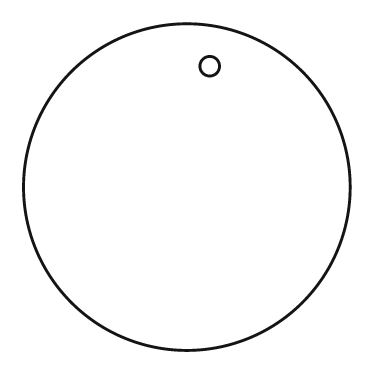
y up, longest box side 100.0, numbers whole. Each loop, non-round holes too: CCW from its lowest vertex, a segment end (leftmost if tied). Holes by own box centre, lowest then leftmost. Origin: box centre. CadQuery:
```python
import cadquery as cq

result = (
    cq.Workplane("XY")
    .moveTo(0.0, 0.0)
    .circle(50.0)
    .moveTo(7.0, 37.0)
    .circle(3.0)
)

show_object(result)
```